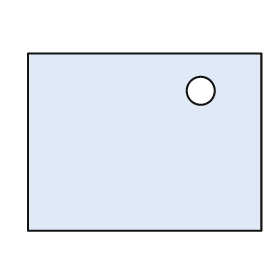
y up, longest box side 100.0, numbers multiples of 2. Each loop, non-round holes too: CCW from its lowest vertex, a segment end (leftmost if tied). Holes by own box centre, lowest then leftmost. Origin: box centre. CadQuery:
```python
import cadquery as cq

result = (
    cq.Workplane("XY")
    .moveTo(-50.0, -38.0)
    .lineTo(50.0, -38.0)
    .lineTo(50.0, 38.0)
    .lineTo(-50.0, 38.0)
    .close()
    .moveTo(24.0, 22.0)
    .circle(6.0)
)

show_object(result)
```